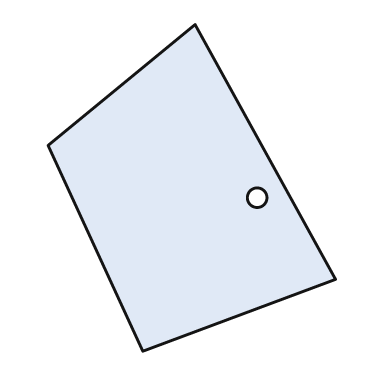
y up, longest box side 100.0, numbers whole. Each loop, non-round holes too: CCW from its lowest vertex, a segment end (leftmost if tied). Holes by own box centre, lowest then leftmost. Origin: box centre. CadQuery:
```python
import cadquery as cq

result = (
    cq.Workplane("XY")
    .moveTo(-15.0, -50.0)
    .lineTo(44.0, -28.0)
    .lineTo(1.0, 50.0)
    .lineTo(-44.0, 13.0)
    .close()
    .moveTo(20.0, -3.0)
    .circle(3.0)
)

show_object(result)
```